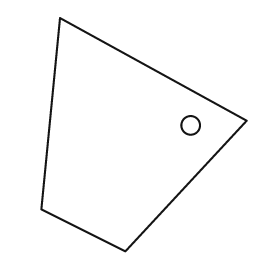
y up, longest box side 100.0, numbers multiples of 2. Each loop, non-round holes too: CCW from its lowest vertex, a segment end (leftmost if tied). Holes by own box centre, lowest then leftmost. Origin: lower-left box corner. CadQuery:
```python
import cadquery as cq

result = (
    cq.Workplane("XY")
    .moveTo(36.0, 0.0)
    .lineTo(88.0, 56.0)
    .lineTo(8.0, 100.0)
    .lineTo(0.0, 18.0)
    .close()
    .moveTo(64.0, 54.0)
    .circle(4.0)
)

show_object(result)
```